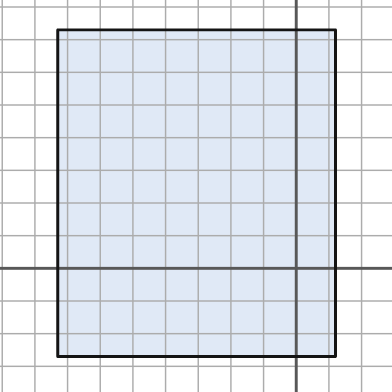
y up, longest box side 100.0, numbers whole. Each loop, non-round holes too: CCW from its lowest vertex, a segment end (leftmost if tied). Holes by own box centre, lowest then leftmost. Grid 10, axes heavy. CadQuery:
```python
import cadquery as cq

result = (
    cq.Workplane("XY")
    .moveTo(-73.0, -27.0)
    .lineTo(12.0, -27.0)
    .lineTo(12.0, 73.0)
    .lineTo(-73.0, 73.0)
    .close()
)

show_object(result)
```